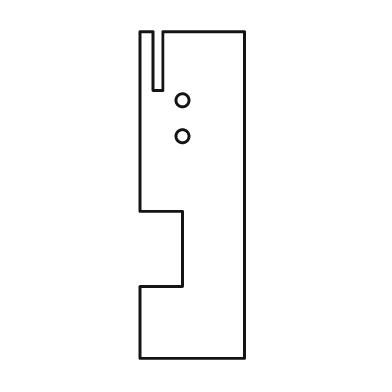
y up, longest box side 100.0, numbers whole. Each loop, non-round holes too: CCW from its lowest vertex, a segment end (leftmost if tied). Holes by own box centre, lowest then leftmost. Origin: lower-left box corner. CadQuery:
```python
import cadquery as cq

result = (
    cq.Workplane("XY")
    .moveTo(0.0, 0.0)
    .lineTo(32.0, 0.0)
    .lineTo(32.0, 100.0)
    .lineTo(7.0, 100.0)
    .lineTo(7.0, 82.0)
    .lineTo(4.0, 82.0)
    .lineTo(4.0, 100.0)
    .lineTo(0.0, 100.0)
    .lineTo(0.0, 45.0)
    .lineTo(13.0, 45.0)
    .lineTo(13.0, 22.0)
    .lineTo(0.0, 22.0)
    .close()
    .moveTo(13.0, 68.0)
    .circle(2.0)
    .moveTo(13.0, 79.0)
    .circle(2.0)
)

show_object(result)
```